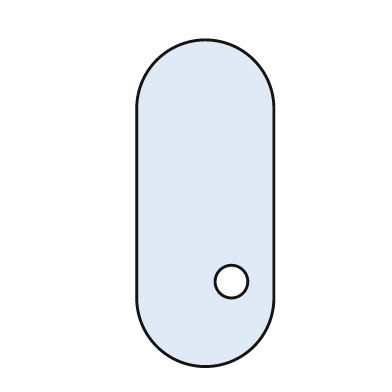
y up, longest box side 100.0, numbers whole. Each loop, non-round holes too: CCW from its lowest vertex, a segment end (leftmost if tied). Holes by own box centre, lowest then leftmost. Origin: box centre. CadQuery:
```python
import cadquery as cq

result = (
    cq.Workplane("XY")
    .moveTo(-21.0, -29.0)
    .threePointArc((0.0, -50.0), (21.0, -29.0))
    .lineTo(21.0, 29.0)
    .threePointArc((0.0, 50.0), (-21.0, 29.0))
    .close()
    .moveTo(8.0, -24.0)
    .circle(5.0)
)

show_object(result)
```